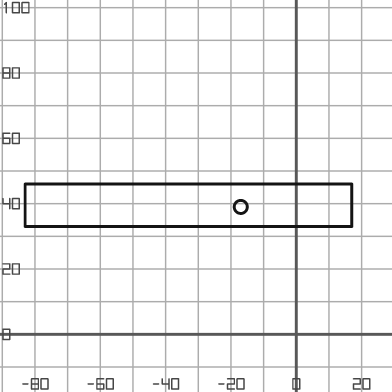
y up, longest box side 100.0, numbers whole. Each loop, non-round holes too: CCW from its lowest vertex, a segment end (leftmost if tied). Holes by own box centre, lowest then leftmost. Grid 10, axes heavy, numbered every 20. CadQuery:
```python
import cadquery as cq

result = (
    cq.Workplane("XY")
    .moveTo(-83.0, 33.0)
    .lineTo(17.0, 33.0)
    .lineTo(17.0, 46.0)
    .lineTo(-83.0, 46.0)
    .close()
    .moveTo(-17.0, 39.0)
    .circle(2.0)
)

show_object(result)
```